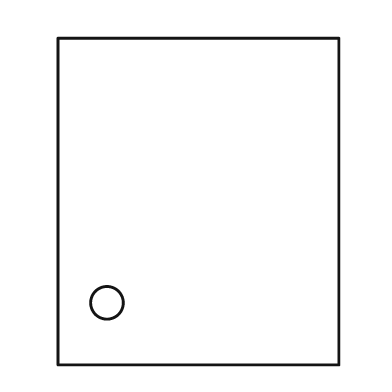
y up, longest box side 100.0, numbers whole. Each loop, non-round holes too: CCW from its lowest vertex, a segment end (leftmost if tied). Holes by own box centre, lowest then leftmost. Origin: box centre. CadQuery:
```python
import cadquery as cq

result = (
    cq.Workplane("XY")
    .moveTo(-43.0, -50.0)
    .lineTo(43.0, -50.0)
    .lineTo(43.0, 50.0)
    .lineTo(-43.0, 50.0)
    .close()
    .moveTo(-28.0, -31.0)
    .circle(5.0)
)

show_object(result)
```